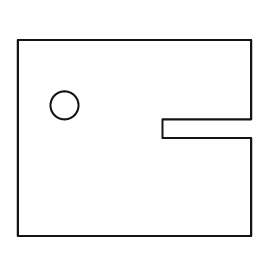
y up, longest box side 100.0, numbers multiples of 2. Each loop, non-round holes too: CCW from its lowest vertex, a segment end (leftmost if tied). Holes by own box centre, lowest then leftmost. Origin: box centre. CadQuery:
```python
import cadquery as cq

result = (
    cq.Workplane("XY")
    .moveTo(-50.0, -42.0)
    .lineTo(50.0, -42.0)
    .lineTo(50.0, 0.0)
    .lineTo(12.0, 0.0)
    .lineTo(12.0, 8.0)
    .lineTo(50.0, 8.0)
    .lineTo(50.0, 42.0)
    .lineTo(-50.0, 42.0)
    .close()
    .moveTo(-30.0, 14.0)
    .circle(6.0)
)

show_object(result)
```